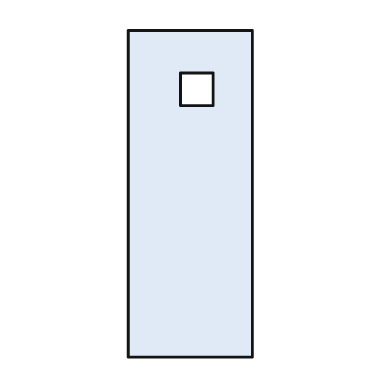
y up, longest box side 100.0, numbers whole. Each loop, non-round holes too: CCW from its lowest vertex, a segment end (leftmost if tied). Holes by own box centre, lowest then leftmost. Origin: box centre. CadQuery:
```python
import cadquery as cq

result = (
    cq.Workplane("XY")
    .moveTo(-19.0, -50.0)
    .lineTo(19.0, -50.0)
    .lineTo(19.0, 50.0)
    .lineTo(-19.0, 50.0)
    .close()
    .moveTo(-3.0, 27.0)
    .lineTo(7.0, 27.0)
    .lineTo(7.0, 37.0)
    .lineTo(-3.0, 37.0)
    .close()
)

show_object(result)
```